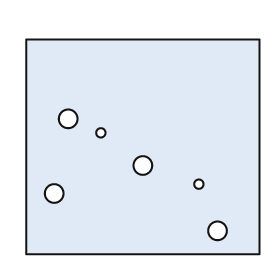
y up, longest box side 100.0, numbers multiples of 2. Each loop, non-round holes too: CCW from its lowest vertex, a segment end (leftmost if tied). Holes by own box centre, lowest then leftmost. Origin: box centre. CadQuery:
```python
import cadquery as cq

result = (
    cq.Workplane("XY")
    .moveTo(-50.0, -46.0)
    .lineTo(50.0, -46.0)
    .lineTo(50.0, 46.0)
    .lineTo(-50.0, 46.0)
    .close()
    .moveTo(32.0, -36.0)
    .circle(4.0)
    .moveTo(-38.0, -20.0)
    .circle(4.0)
    .moveTo(24.0, -16.0)
    .circle(2.0)
    .moveTo(0.0, -8.0)
    .circle(4.0)
    .moveTo(-18.0, 6.0)
    .circle(2.0)
    .moveTo(-32.0, 12.0)
    .circle(4.0)
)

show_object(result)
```